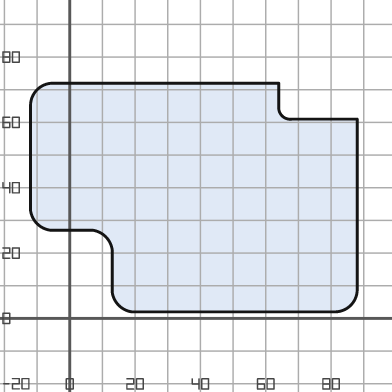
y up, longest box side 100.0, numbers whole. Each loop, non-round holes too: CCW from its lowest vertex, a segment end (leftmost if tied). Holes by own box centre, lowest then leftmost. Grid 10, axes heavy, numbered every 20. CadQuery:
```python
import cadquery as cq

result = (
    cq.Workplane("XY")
    .moveTo(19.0, 2.0)
    .lineTo(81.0, 2.0)
    .threePointArc((86.0, 4.0), (88.0, 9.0))
    .lineTo(88.0, 61.0)
    .lineTo(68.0, 61.0)
    .threePointArc((65.0, 62.0), (64.0, 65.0))
    .lineTo(64.0, 72.0)
    .lineTo(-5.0, 72.0)
    .threePointArc((-10.0, 70.0), (-12.0, 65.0))
    .lineTo(-12.0, 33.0)
    .threePointArc((-10.0, 29.0), (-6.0, 27.0))
    .lineTo(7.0, 27.0)
    .threePointArc((11.0, 25.0), (13.0, 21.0))
    .lineTo(13.0, 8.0)
    .threePointArc((15.0, 4.0), (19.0, 2.0))
    .close()
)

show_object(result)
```